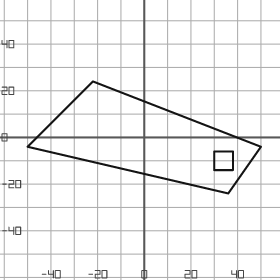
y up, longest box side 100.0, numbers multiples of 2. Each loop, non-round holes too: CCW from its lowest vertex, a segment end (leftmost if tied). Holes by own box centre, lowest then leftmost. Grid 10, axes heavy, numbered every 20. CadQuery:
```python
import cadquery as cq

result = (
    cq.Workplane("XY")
    .moveTo(36.0, -24.0)
    .lineTo(50.0, -4.0)
    .lineTo(-22.0, 24.0)
    .lineTo(-50.0, -4.0)
    .close()
    .moveTo(30.0, -14.0)
    .lineTo(38.0, -14.0)
    .lineTo(38.0, -6.0)
    .lineTo(30.0, -6.0)
    .close()
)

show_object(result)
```